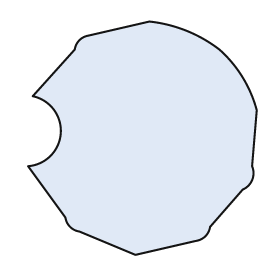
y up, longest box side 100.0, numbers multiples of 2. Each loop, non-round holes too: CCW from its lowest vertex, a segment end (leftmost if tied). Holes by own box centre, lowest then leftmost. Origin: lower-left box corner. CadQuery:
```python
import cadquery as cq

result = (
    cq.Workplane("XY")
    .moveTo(46.0, 0.0)
    .lineTo(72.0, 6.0)
    .threePointArc((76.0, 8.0), (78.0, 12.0))
    .lineTo(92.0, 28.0)
    .threePointArc((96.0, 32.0), (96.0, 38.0))
    .lineTo(98.0, 62.0)
    .threePointArc((92.0, 76.0), (82.0, 88.0))
    .threePointArc((68.0, 96.0), (52.0, 100.0))
    .lineTo(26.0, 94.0)
    .threePointArc((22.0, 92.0), (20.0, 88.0))
    .lineTo(2.0, 68.0)
    .threePointArc((14.0, 52.0), (0.0, 38.0))
    .lineTo(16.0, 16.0)
    .threePointArc((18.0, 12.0), (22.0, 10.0))
    .close()
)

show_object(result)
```